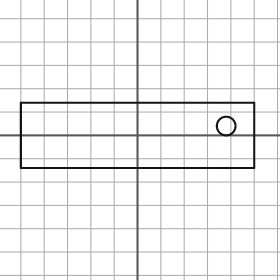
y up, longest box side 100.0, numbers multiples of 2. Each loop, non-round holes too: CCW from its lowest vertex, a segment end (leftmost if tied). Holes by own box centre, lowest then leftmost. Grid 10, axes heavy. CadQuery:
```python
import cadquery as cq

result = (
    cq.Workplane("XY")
    .moveTo(-50.0, -14.0)
    .lineTo(50.0, -14.0)
    .lineTo(50.0, 14.0)
    .lineTo(-50.0, 14.0)
    .close()
    .moveTo(38.0, 4.0)
    .circle(4.0)
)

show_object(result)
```